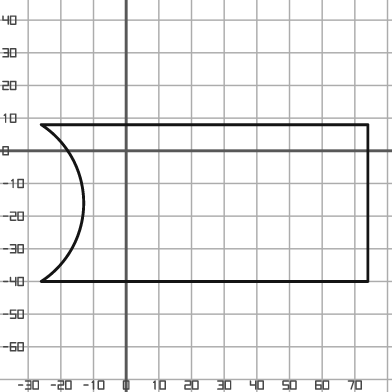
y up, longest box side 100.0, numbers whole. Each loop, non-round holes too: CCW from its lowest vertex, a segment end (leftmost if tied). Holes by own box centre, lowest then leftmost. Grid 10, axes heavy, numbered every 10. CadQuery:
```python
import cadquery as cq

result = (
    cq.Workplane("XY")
    .moveTo(-26.0, -40.0)
    .lineTo(74.0, -40.0)
    .lineTo(74.0, 8.0)
    .lineTo(-26.0, 8.0)
    .threePointArc((-13.0, -16.0), (-26.0, -40.0))
    .close()
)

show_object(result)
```